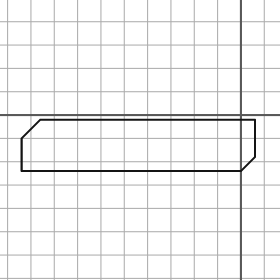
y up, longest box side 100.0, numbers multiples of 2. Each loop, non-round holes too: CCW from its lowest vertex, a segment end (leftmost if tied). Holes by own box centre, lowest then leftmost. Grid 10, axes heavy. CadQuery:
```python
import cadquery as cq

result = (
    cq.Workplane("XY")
    .moveTo(-94.0, -24.0)
    .lineTo(0.0, -24.0)
    .lineTo(6.0, -18.0)
    .lineTo(6.0, -2.0)
    .lineTo(-86.0, -2.0)
    .lineTo(-94.0, -10.0)
    .close()
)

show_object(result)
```